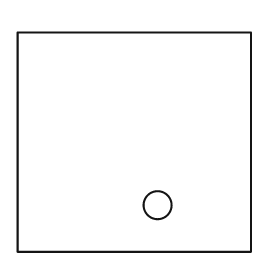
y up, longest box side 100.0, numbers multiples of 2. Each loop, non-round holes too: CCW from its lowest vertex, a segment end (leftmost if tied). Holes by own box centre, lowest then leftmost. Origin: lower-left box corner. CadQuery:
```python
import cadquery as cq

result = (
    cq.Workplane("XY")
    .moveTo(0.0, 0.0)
    .lineTo(100.0, 0.0)
    .lineTo(100.0, 94.0)
    .lineTo(0.0, 94.0)
    .close()
    .moveTo(60.0, 20.0)
    .circle(6.0)
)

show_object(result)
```